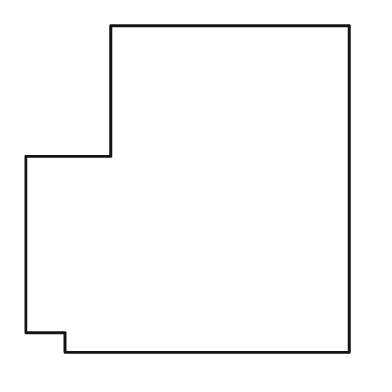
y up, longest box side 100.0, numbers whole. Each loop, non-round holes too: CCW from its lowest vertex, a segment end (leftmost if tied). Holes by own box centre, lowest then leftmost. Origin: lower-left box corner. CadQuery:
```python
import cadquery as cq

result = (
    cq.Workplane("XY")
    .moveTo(12.0, 0.0)
    .lineTo(99.0, 0.0)
    .lineTo(99.0, 100.0)
    .lineTo(26.0, 100.0)
    .lineTo(26.0, 60.0)
    .lineTo(0.0, 60.0)
    .lineTo(0.0, 6.0)
    .lineTo(12.0, 6.0)
    .close()
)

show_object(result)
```